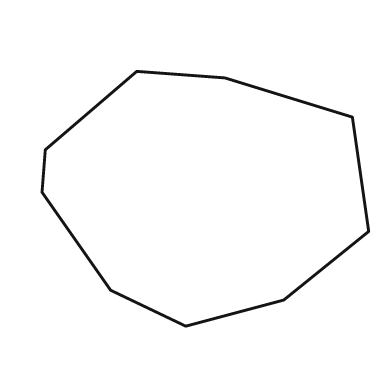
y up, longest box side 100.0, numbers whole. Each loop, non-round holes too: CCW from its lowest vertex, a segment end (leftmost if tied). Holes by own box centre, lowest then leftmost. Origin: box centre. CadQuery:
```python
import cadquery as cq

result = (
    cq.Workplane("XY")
    .moveTo(-6.0, -39.0)
    .lineTo(24.0, -31.0)
    .lineTo(50.0, -10.0)
    .lineTo(45.0, 25.0)
    .lineTo(6.0, 37.0)
    .lineTo(-21.0, 39.0)
    .lineTo(-49.0, 15.0)
    .lineTo(-50.0, 2.0)
    .lineTo(-29.0, -28.0)
    .close()
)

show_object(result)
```